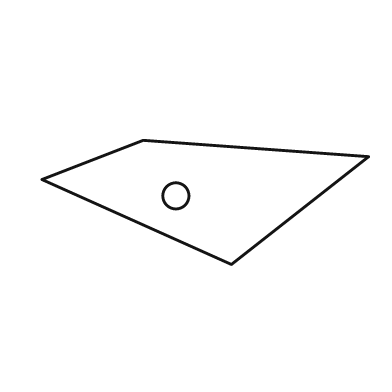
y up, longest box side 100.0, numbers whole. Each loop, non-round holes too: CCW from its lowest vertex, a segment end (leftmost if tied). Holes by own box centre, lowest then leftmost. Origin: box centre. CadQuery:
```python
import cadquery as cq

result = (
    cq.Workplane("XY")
    .moveTo(8.0, -19.0)
    .lineTo(50.0, 14.0)
    .lineTo(-19.0, 19.0)
    .lineTo(-50.0, 7.0)
    .close()
    .moveTo(-9.0, 2.0)
    .circle(4.0)
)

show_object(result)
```